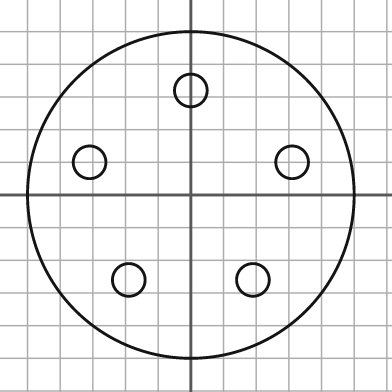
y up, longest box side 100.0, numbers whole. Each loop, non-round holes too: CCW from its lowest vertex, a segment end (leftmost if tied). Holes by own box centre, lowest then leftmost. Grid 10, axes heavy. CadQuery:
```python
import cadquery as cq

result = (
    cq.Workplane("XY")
    .moveTo(0.0, 0.0)
    .circle(50.0)
    .moveTo(-19.0, -26.0)
    .circle(5.0)
    .moveTo(19.0, -26.0)
    .circle(5.0)
    .moveTo(-31.0, 10.0)
    .circle(5.0)
    .moveTo(31.0, 10.0)
    .circle(5.0)
    .moveTo(0.0, 32.0)
    .circle(5.0)
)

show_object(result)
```